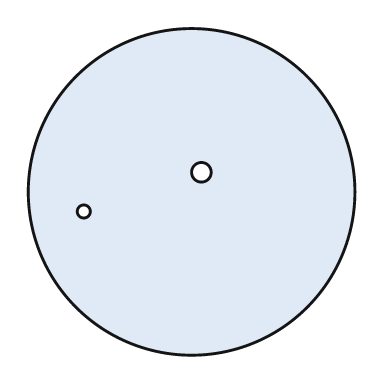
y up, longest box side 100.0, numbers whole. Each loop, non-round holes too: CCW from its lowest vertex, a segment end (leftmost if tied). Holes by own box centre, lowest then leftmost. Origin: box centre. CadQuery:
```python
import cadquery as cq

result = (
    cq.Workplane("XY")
    .moveTo(0.0, 0.0)
    .circle(50.0)
    .moveTo(-33.0, -6.0)
    .circle(2.0)
    .moveTo(3.0, 6.0)
    .circle(3.0)
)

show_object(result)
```